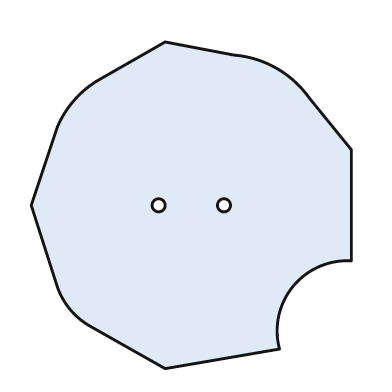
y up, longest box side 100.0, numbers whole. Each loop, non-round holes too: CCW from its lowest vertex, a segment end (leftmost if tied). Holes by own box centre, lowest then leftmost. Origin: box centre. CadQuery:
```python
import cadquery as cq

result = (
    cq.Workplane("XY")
    .moveTo(-8.0, -50.0)
    .lineTo(27.0, -44.0)
    .threePointArc((31.0, -25.0), (49.0, -17.0))
    .lineTo(49.0, 17.0)
    .lineTo(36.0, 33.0)
    .threePointArc((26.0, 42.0), (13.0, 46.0))
    .lineTo(-8.0, 50.0)
    .lineTo(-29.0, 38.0)
    .threePointArc((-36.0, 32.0), (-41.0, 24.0))
    .lineTo(-49.0, 0.0)
    .lineTo(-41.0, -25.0)
    .threePointArc((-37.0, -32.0), (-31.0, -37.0))
    .close()
    .moveTo(-10.0, 0.0)
    .circle(2.0)
    .moveTo(10.0, 0.0)
    .circle(2.0)
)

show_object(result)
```